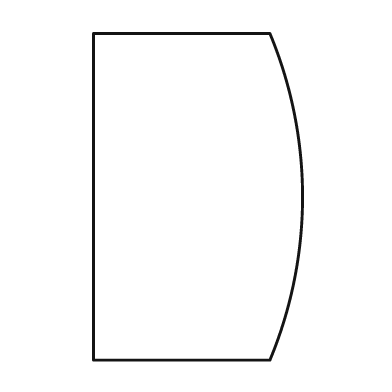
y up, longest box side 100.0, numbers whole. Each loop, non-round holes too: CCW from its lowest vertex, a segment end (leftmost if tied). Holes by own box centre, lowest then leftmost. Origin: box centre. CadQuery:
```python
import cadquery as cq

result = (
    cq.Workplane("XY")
    .moveTo(-32.0, -50.0)
    .lineTo(22.0, -50.0)
    .threePointArc((32.0, 0.0), (22.0, 50.0))
    .lineTo(-32.0, 50.0)
    .close()
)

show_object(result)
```